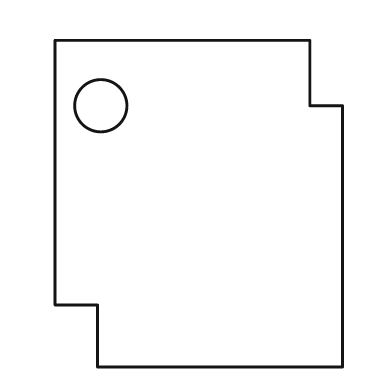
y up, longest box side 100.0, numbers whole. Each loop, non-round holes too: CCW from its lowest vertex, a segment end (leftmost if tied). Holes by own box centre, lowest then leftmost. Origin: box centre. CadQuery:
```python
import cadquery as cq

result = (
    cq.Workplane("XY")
    .moveTo(-31.0, -50.0)
    .lineTo(44.0, -50.0)
    .lineTo(44.0, 30.0)
    .lineTo(34.0, 30.0)
    .lineTo(34.0, 50.0)
    .lineTo(-44.0, 50.0)
    .lineTo(-44.0, -31.0)
    .lineTo(-31.0, -31.0)
    .close()
    .moveTo(-30.0, 30.0)
    .circle(8.0)
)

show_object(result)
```